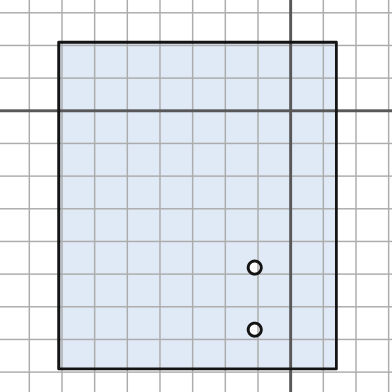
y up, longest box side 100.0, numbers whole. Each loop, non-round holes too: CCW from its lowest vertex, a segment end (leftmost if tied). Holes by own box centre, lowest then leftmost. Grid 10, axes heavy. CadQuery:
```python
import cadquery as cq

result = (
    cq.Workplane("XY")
    .moveTo(-71.0, -79.0)
    .lineTo(14.0, -79.0)
    .lineTo(14.0, 21.0)
    .lineTo(-71.0, 21.0)
    .close()
    .moveTo(-11.0, -67.0)
    .circle(2.0)
    .moveTo(-11.0, -48.0)
    .circle(2.0)
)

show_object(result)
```